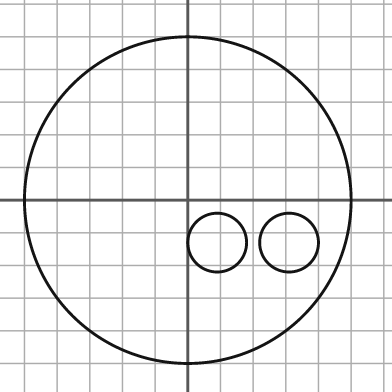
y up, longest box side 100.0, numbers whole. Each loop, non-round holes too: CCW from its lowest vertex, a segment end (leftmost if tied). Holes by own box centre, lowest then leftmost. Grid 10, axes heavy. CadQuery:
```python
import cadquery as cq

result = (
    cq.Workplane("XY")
    .moveTo(0.0, 0.0)
    .circle(50.0)
    .moveTo(9.0, -13.0)
    .circle(9.0)
    .moveTo(31.0, -13.0)
    .circle(9.0)
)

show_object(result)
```